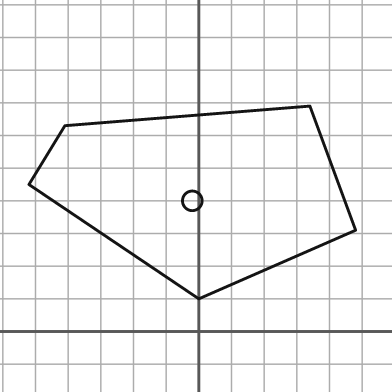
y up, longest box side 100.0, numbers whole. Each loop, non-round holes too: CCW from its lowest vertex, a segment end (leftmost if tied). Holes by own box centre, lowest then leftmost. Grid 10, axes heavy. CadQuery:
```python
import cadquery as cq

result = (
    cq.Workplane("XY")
    .moveTo(0.0, 10.0)
    .lineTo(48.0, 31.0)
    .lineTo(34.0, 69.0)
    .lineTo(-41.0, 63.0)
    .lineTo(-52.0, 45.0)
    .close()
    .moveTo(-2.0, 40.0)
    .circle(3.0)
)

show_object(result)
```